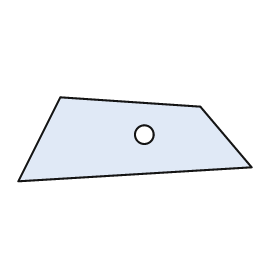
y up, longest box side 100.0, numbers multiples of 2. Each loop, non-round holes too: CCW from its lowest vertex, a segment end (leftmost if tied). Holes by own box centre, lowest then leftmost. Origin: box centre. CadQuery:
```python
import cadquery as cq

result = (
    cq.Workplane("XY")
    .moveTo(-50.0, -18.0)
    .lineTo(50.0, -12.0)
    .lineTo(28.0, 14.0)
    .lineTo(-32.0, 18.0)
    .close()
    .moveTo(4.0, 2.0)
    .circle(4.0)
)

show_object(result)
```